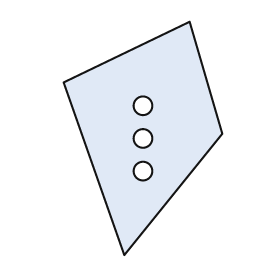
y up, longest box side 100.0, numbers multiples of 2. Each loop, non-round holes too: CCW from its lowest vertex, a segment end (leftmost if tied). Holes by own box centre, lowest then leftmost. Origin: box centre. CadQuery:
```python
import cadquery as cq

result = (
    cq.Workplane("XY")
    .moveTo(-8.0, -50.0)
    .lineTo(34.0, 2.0)
    .lineTo(20.0, 50.0)
    .lineTo(-34.0, 24.0)
    .close()
    .moveTo(0.0, -14.0)
    .circle(4.0)
    .moveTo(0.0, 0.0)
    .circle(4.0)
    .moveTo(0.0, 14.0)
    .circle(4.0)
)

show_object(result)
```